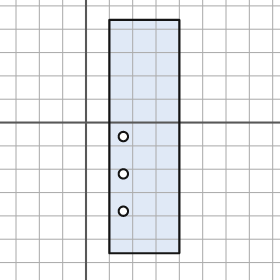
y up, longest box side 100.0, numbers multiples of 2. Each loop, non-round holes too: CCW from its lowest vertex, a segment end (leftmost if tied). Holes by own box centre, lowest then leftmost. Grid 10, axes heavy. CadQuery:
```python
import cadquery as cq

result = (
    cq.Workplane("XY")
    .moveTo(10.0, -56.0)
    .lineTo(40.0, -56.0)
    .lineTo(40.0, 44.0)
    .lineTo(10.0, 44.0)
    .close()
    .moveTo(16.0, -38.0)
    .circle(2.0)
    .moveTo(16.0, -22.0)
    .circle(2.0)
    .moveTo(16.0, -6.0)
    .circle(2.0)
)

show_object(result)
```